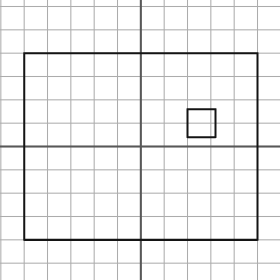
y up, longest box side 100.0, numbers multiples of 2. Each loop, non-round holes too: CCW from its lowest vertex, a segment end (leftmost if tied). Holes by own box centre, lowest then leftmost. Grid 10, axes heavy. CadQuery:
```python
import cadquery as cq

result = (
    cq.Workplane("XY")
    .moveTo(-50.0, -40.0)
    .lineTo(50.0, -40.0)
    .lineTo(50.0, 40.0)
    .lineTo(-50.0, 40.0)
    .close()
    .moveTo(20.0, 4.0)
    .lineTo(32.0, 4.0)
    .lineTo(32.0, 16.0)
    .lineTo(20.0, 16.0)
    .close()
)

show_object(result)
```